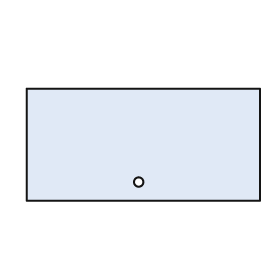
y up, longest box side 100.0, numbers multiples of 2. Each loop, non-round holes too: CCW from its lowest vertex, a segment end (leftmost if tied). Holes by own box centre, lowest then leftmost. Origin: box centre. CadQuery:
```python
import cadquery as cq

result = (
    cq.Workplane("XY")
    .moveTo(-50.0, -24.0)
    .lineTo(50.0, -24.0)
    .lineTo(50.0, 24.0)
    .lineTo(-50.0, 24.0)
    .close()
    .moveTo(-2.0, -16.0)
    .circle(2.0)
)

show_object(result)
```